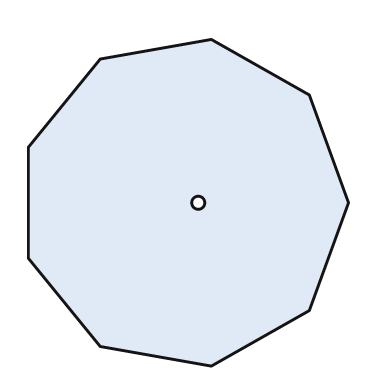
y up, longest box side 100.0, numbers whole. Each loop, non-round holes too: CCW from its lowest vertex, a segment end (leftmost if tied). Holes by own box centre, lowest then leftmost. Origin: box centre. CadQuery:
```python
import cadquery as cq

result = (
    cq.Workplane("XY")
    .moveTo(7.0, -50.0)
    .lineTo(37.0, -33.0)
    .lineTo(49.0, 0.0)
    .lineTo(37.0, 33.0)
    .lineTo(7.0, 50.0)
    .lineTo(-27.0, 44.0)
    .lineTo(-49.0, 17.0)
    .lineTo(-49.0, -17.0)
    .lineTo(-27.0, -44.0)
    .close()
    .moveTo(3.0, 0.0)
    .circle(2.0)
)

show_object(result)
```